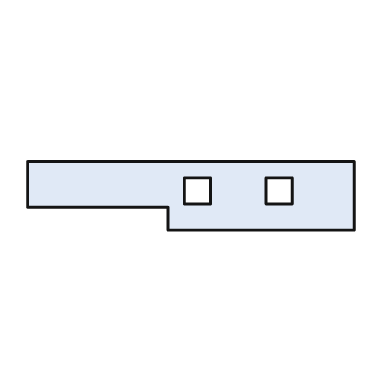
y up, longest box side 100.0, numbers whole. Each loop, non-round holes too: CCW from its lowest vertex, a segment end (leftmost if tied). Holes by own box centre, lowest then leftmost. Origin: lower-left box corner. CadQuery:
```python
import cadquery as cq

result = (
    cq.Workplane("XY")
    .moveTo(43.0, 0.0)
    .lineTo(100.0, 0.0)
    .lineTo(100.0, 21.0)
    .lineTo(0.0, 21.0)
    .lineTo(0.0, 7.0)
    .lineTo(43.0, 7.0)
    .close()
    .moveTo(48.0, 8.0)
    .lineTo(56.0, 8.0)
    .lineTo(56.0, 16.0)
    .lineTo(48.0, 16.0)
    .close()
    .moveTo(73.0, 8.0)
    .lineTo(81.0, 8.0)
    .lineTo(81.0, 16.0)
    .lineTo(73.0, 16.0)
    .close()
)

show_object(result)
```